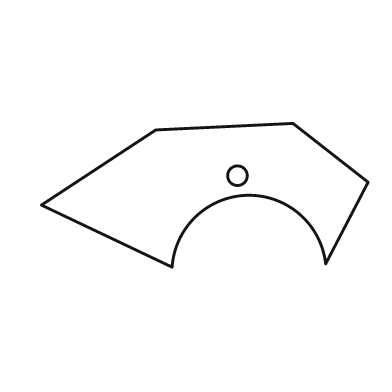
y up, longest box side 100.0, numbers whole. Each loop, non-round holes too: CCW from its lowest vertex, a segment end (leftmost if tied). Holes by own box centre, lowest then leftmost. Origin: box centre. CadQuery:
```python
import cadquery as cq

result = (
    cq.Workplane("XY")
    .moveTo(-10.0, -22.0)
    .threePointArc((13.0, 0.0), (37.0, -21.0))
    .lineTo(50.0, 4.0)
    .lineTo(27.0, 22.0)
    .lineTo(-15.0, 20.0)
    .lineTo(-50.0, -3.0)
    .close()
    .moveTo(10.0, 6.0)
    .circle(3.0)
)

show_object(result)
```